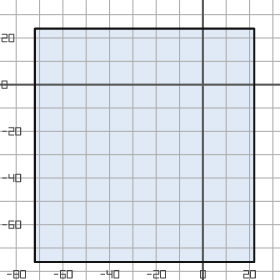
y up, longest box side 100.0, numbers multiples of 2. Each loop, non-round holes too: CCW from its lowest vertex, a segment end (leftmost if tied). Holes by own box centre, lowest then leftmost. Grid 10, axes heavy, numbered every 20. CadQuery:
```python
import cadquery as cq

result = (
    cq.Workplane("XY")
    .moveTo(-72.0, -76.0)
    .lineTo(22.0, -76.0)
    .lineTo(22.0, 24.0)
    .lineTo(-72.0, 24.0)
    .close()
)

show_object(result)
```